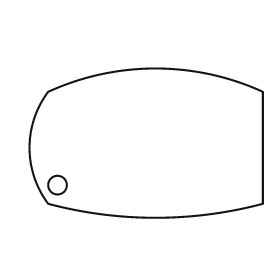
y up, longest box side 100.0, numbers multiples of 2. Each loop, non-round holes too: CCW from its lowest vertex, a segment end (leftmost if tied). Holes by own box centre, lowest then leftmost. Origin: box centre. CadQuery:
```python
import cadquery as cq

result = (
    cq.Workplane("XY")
    .moveTo(-42.0, -26.0)
    .threePointArc((4.0, -32.0), (50.0, -26.0))
    .lineTo(50.0, 22.0)
    .threePointArc((4.0, 32.0), (-42.0, 22.0))
    .threePointArc((-50.0, -2.0), (-42.0, -26.0))
    .close()
    .moveTo(-38.0, -18.0)
    .circle(4.0)
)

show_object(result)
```